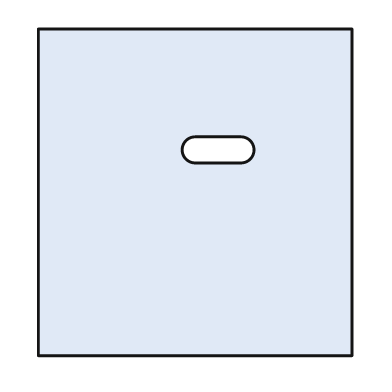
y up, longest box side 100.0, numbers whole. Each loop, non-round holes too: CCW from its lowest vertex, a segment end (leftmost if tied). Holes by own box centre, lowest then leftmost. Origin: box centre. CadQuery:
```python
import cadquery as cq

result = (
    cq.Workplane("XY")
    .moveTo(-48.0, -50.0)
    .lineTo(48.0, -50.0)
    .lineTo(48.0, 50.0)
    .lineTo(-48.0, 50.0)
    .close()
    .moveTo(0.0, 9.0)
    .lineTo(14.0, 9.0)
    .threePointArc((18.0, 13.0), (14.0, 17.0))
    .lineTo(0.0, 17.0)
    .threePointArc((-4.0, 13.0), (0.0, 9.0))
    .close()
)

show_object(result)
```